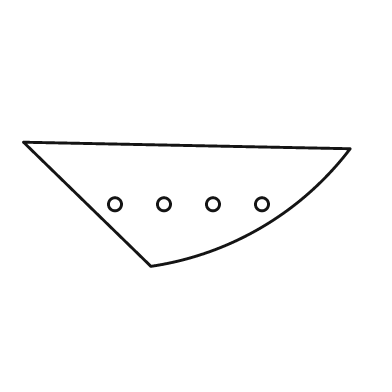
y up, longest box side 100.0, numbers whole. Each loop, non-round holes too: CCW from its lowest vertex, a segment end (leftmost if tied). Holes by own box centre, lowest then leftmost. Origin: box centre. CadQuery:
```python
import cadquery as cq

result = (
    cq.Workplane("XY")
    .moveTo(-11.0, -19.0)
    .threePointArc((23.0, -7.0), (50.0, 17.0))
    .lineTo(-50.0, 19.0)
    .close()
    .moveTo(-22.0, 0.0)
    .circle(2.0)
    .moveTo(-7.0, 0.0)
    .circle(2.0)
    .moveTo(8.0, 0.0)
    .circle(2.0)
    .moveTo(23.0, 0.0)
    .circle(2.0)
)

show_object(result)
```